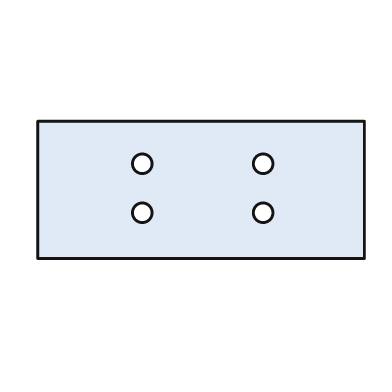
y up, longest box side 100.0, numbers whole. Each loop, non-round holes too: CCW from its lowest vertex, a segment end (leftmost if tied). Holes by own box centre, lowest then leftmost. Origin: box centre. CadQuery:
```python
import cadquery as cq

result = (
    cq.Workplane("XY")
    .moveTo(-50.0, -21.0)
    .lineTo(50.0, -21.0)
    .lineTo(50.0, 21.0)
    .lineTo(-50.0, 21.0)
    .close()
    .moveTo(-18.0, -7.0)
    .circle(3.0)
    .moveTo(19.0, -7.0)
    .circle(3.0)
    .moveTo(-18.0, 8.0)
    .circle(3.0)
    .moveTo(19.0, 8.0)
    .circle(3.0)
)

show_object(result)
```